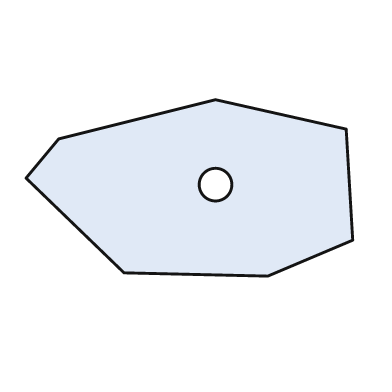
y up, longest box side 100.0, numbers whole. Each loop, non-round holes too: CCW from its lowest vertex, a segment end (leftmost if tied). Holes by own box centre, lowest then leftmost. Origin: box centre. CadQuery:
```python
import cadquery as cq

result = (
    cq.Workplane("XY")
    .moveTo(24.0, -27.0)
    .lineTo(50.0, -16.0)
    .lineTo(48.0, 18.0)
    .lineTo(8.0, 27.0)
    .lineTo(-40.0, 15.0)
    .lineTo(-50.0, 3.0)
    .lineTo(-20.0, -26.0)
    .close()
    .moveTo(8.0, 1.0)
    .circle(5.0)
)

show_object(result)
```